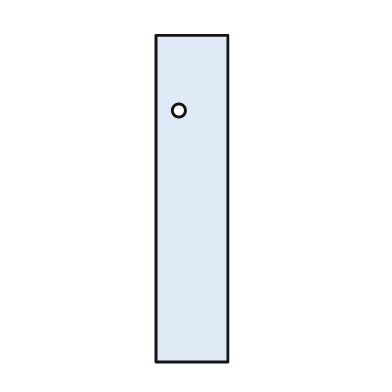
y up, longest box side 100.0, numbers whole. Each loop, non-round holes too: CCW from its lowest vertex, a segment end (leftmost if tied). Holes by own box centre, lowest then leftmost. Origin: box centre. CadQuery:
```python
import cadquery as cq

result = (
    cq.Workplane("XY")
    .moveTo(-11.0, -50.0)
    .lineTo(11.0, -50.0)
    .lineTo(11.0, 50.0)
    .lineTo(-11.0, 50.0)
    .close()
    .moveTo(-4.0, 27.0)
    .circle(2.0)
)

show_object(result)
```